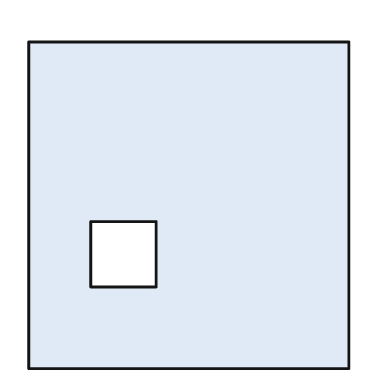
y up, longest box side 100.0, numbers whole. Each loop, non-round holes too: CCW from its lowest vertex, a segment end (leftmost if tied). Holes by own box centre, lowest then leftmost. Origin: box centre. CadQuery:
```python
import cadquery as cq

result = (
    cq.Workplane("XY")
    .moveTo(-49.0, -50.0)
    .lineTo(49.0, -50.0)
    .lineTo(49.0, 50.0)
    .lineTo(-49.0, 50.0)
    .close()
    .moveTo(-30.0, -25.0)
    .lineTo(-10.0, -25.0)
    .lineTo(-10.0, -5.0)
    .lineTo(-30.0, -5.0)
    .close()
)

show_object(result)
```